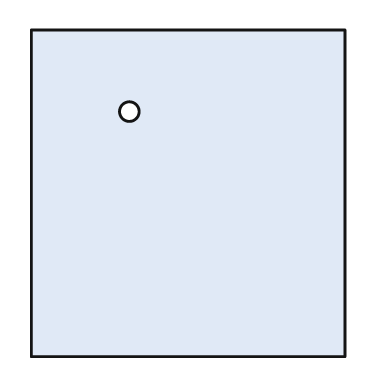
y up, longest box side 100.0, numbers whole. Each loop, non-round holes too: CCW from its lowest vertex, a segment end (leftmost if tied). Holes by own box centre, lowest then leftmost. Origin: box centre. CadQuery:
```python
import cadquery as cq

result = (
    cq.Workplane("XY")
    .moveTo(-48.0, -50.0)
    .lineTo(48.0, -50.0)
    .lineTo(48.0, 50.0)
    .lineTo(-48.0, 50.0)
    .close()
    .moveTo(-18.0, 25.0)
    .circle(3.0)
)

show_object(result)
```